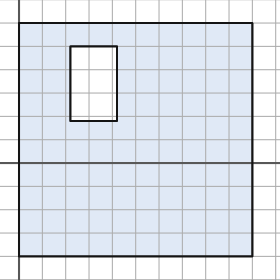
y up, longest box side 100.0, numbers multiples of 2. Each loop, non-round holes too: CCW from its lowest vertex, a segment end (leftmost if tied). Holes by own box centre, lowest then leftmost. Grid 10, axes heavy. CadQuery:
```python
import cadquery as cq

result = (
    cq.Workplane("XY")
    .moveTo(0.0, -40.0)
    .lineTo(100.0, -40.0)
    .lineTo(100.0, 60.0)
    .lineTo(0.0, 60.0)
    .close()
    .moveTo(22.0, 18.0)
    .lineTo(42.0, 18.0)
    .lineTo(42.0, 50.0)
    .lineTo(22.0, 50.0)
    .close()
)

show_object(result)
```